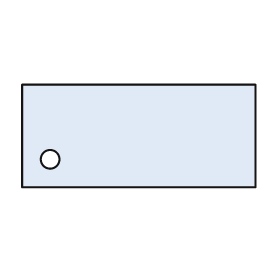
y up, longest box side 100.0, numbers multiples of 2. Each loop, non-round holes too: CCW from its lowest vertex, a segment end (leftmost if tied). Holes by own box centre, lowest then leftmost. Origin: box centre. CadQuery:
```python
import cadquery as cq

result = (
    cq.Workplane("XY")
    .moveTo(-50.0, -22.0)
    .lineTo(50.0, -22.0)
    .lineTo(50.0, 22.0)
    .lineTo(-50.0, 22.0)
    .close()
    .moveTo(-38.0, -10.0)
    .circle(4.0)
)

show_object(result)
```